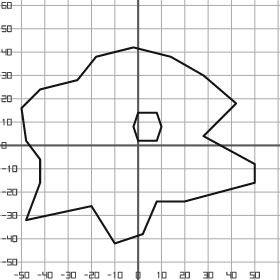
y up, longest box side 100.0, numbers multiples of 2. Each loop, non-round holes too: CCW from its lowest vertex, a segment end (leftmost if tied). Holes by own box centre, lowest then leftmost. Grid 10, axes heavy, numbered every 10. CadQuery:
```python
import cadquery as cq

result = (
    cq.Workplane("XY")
    .moveTo(-10.0, -42.0)
    .lineTo(2.0, -38.0)
    .lineTo(8.0, -24.0)
    .lineTo(20.0, -24.0)
    .lineTo(50.0, -16.0)
    .lineTo(50.0, -8.0)
    .lineTo(28.0, 4.0)
    .lineTo(42.0, 18.0)
    .lineTo(28.0, 30.0)
    .lineTo(14.0, 38.0)
    .lineTo(-2.0, 42.0)
    .lineTo(-18.0, 38.0)
    .lineTo(-26.0, 28.0)
    .lineTo(-42.0, 24.0)
    .lineTo(-50.0, 16.0)
    .lineTo(-48.0, 2.0)
    .lineTo(-42.0, -6.0)
    .lineTo(-42.0, -16.0)
    .lineTo(-48.0, -32.0)
    .lineTo(-20.0, -26.0)
    .close()
    .moveTo(0.0, 2.0)
    .lineTo(8.0, 2.0)
    .lineTo(10.0, 8.0)
    .lineTo(8.0, 14.0)
    .lineTo(0.0, 14.0)
    .lineTo(-2.0, 8.0)
    .close()
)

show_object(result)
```